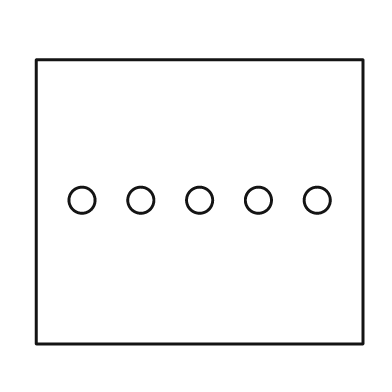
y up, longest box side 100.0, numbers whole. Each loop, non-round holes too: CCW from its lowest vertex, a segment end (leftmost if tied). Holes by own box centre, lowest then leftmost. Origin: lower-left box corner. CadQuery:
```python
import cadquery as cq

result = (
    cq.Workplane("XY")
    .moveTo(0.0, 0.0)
    .lineTo(100.0, 0.0)
    .lineTo(100.0, 87.0)
    .lineTo(0.0, 87.0)
    .close()
    .moveTo(14.0, 44.0)
    .circle(4.0)
    .moveTo(32.0, 44.0)
    .circle(4.0)
    .moveTo(50.0, 44.0)
    .circle(4.0)
    .moveTo(68.0, 44.0)
    .circle(4.0)
    .moveTo(86.0, 44.0)
    .circle(4.0)
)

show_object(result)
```